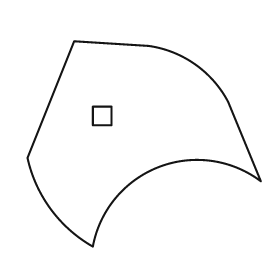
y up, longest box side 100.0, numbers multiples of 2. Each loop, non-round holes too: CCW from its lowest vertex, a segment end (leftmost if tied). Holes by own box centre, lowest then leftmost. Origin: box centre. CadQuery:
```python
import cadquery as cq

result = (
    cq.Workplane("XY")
    .moveTo(-22.0, -44.0)
    .threePointArc((6.0, -10.0), (50.0, -16.0))
    .lineTo(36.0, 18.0)
    .threePointArc((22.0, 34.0), (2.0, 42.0))
    .lineTo(-30.0, 44.0)
    .lineTo(-50.0, -6.0)
    .threePointArc((-40.0, -28.0), (-22.0, -44.0))
    .close()
    .moveTo(-22.0, 8.0)
    .lineTo(-14.0, 8.0)
    .lineTo(-14.0, 16.0)
    .lineTo(-22.0, 16.0)
    .close()
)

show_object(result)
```